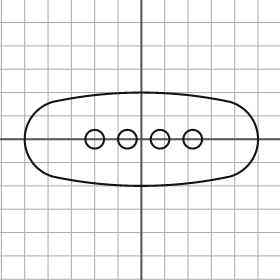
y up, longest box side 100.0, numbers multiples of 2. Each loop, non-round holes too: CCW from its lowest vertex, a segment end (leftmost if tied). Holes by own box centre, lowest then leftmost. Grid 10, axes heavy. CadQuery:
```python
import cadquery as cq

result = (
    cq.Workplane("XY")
    .moveTo(-38.0, -16.0)
    .threePointArc((0.0, -20.0), (38.0, -16.0))
    .threePointArc((50.0, 0.0), (38.0, 16.0))
    .threePointArc((0.0, 20.0), (-38.0, 16.0))
    .threePointArc((-50.0, 0.0), (-38.0, -16.0))
    .close()
    .moveTo(-20.0, 0.0)
    .circle(4.0)
    .moveTo(-6.0, 0.0)
    .circle(4.0)
    .moveTo(8.0, 0.0)
    .circle(4.0)
    .moveTo(22.0, 0.0)
    .circle(4.0)
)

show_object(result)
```